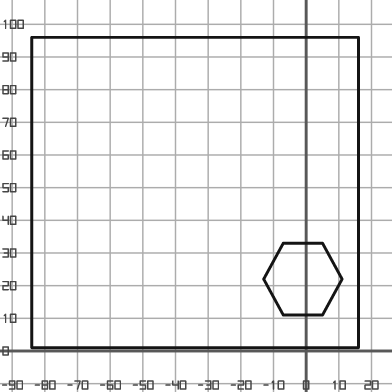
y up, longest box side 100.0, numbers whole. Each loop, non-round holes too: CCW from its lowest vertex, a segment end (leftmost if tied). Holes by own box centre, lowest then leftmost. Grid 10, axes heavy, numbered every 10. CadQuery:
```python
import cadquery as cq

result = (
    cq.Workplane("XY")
    .moveTo(-84.0, 1.0)
    .lineTo(16.0, 1.0)
    .lineTo(16.0, 96.0)
    .lineTo(-84.0, 96.0)
    .close()
    .moveTo(-7.0, 11.0)
    .lineTo(5.0, 11.0)
    .lineTo(11.0, 22.0)
    .lineTo(5.0, 33.0)
    .lineTo(-7.0, 33.0)
    .lineTo(-13.0, 22.0)
    .close()
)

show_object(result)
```